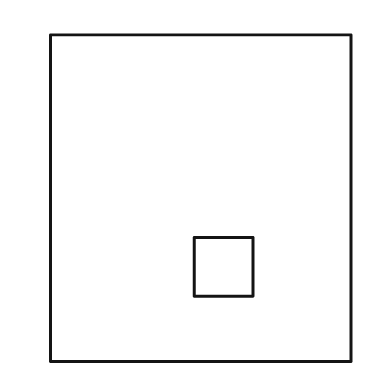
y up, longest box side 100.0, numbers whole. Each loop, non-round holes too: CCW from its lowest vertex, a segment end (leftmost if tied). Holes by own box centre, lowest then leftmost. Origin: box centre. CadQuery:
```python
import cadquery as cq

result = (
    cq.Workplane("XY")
    .moveTo(-46.0, -50.0)
    .lineTo(46.0, -50.0)
    .lineTo(46.0, 50.0)
    .lineTo(-46.0, 50.0)
    .close()
    .moveTo(-2.0, -30.0)
    .lineTo(16.0, -30.0)
    .lineTo(16.0, -12.0)
    .lineTo(-2.0, -12.0)
    .close()
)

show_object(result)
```